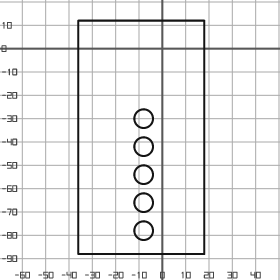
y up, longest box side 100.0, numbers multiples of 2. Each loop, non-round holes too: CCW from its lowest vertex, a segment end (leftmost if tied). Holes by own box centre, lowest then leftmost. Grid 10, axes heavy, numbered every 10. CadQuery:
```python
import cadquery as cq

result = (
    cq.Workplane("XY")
    .moveTo(-36.0, -88.0)
    .lineTo(18.0, -88.0)
    .lineTo(18.0, 12.0)
    .lineTo(-36.0, 12.0)
    .close()
    .moveTo(-8.0, -78.0)
    .circle(4.0)
    .moveTo(-8.0, -66.0)
    .circle(4.0)
    .moveTo(-8.0, -54.0)
    .circle(4.0)
    .moveTo(-8.0, -42.0)
    .circle(4.0)
    .moveTo(-8.0, -30.0)
    .circle(4.0)
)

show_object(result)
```